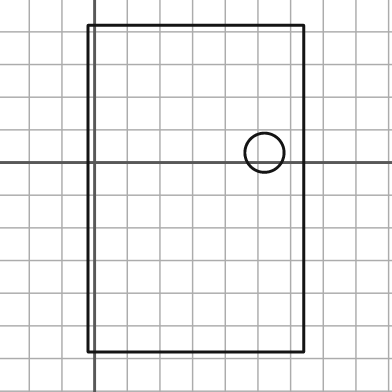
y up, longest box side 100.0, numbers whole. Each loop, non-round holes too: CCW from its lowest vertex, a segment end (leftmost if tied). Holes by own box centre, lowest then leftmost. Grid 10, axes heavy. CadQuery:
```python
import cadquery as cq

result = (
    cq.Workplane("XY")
    .moveTo(-2.0, -58.0)
    .lineTo(64.0, -58.0)
    .lineTo(64.0, 42.0)
    .lineTo(-2.0, 42.0)
    .close()
    .moveTo(52.0, 3.0)
    .circle(6.0)
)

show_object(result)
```